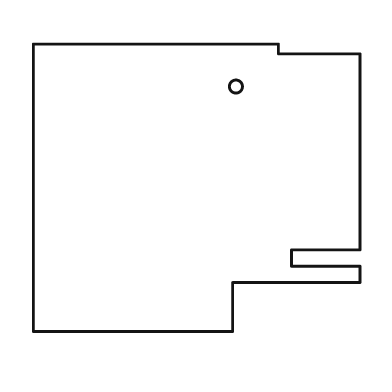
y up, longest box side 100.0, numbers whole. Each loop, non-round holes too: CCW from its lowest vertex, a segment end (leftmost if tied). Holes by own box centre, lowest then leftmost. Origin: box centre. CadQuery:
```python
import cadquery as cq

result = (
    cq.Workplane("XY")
    .moveTo(-50.0, -44.0)
    .lineTo(11.0, -44.0)
    .lineTo(11.0, -29.0)
    .lineTo(50.0, -29.0)
    .lineTo(50.0, -24.0)
    .lineTo(29.0, -24.0)
    .lineTo(29.0, -19.0)
    .lineTo(50.0, -19.0)
    .lineTo(50.0, 41.0)
    .lineTo(25.0, 41.0)
    .lineTo(25.0, 44.0)
    .lineTo(-50.0, 44.0)
    .close()
    .moveTo(12.0, 31.0)
    .circle(2.0)
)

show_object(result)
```